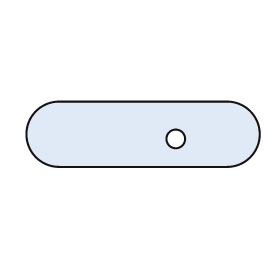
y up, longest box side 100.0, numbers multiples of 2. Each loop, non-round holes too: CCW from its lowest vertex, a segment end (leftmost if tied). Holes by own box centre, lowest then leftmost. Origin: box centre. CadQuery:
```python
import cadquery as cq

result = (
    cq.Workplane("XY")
    .moveTo(-36.0, -14.0)
    .lineTo(36.0, -14.0)
    .threePointArc((50.0, 0.0), (36.0, 14.0))
    .lineTo(-36.0, 14.0)
    .threePointArc((-50.0, 0.0), (-36.0, -14.0))
    .close()
    .moveTo(14.0, -2.0)
    .circle(4.0)
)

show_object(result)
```